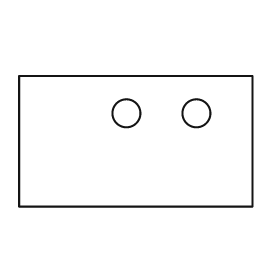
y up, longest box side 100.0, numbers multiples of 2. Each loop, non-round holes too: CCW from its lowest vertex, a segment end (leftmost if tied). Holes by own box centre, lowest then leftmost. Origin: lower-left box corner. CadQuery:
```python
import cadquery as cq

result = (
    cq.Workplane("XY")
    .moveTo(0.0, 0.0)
    .lineTo(100.0, 0.0)
    .lineTo(100.0, 56.0)
    .lineTo(0.0, 56.0)
    .close()
    .moveTo(46.0, 40.0)
    .circle(6.0)
    .moveTo(76.0, 40.0)
    .circle(6.0)
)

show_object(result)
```